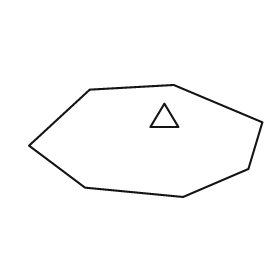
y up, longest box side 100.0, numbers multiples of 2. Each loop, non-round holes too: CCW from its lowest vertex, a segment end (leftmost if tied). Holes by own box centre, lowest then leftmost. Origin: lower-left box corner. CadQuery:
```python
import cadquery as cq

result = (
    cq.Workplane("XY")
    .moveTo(66.0, 0.0)
    .lineTo(94.0, 12.0)
    .lineTo(100.0, 32.0)
    .lineTo(62.0, 48.0)
    .lineTo(26.0, 46.0)
    .lineTo(0.0, 22.0)
    .lineTo(24.0, 4.0)
    .close()
    .moveTo(52.0, 30.0)
    .lineTo(64.0, 30.0)
    .lineTo(58.0, 40.0)
    .close()
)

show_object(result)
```